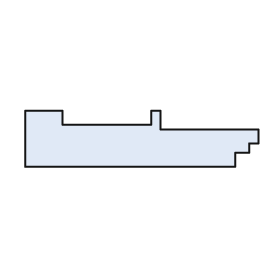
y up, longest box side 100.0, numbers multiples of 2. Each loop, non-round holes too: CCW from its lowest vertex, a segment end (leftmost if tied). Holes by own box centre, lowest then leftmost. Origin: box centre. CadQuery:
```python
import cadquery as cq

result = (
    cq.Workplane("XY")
    .moveTo(-50.0, -12.0)
    .lineTo(40.0, -12.0)
    .lineTo(40.0, -6.0)
    .lineTo(46.0, -6.0)
    .lineTo(46.0, -2.0)
    .lineTo(50.0, -2.0)
    .lineTo(50.0, 4.0)
    .lineTo(8.0, 4.0)
    .lineTo(8.0, 12.0)
    .lineTo(4.0, 12.0)
    .lineTo(4.0, 6.0)
    .lineTo(-34.0, 6.0)
    .lineTo(-34.0, 12.0)
    .lineTo(-50.0, 12.0)
    .close()
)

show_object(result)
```